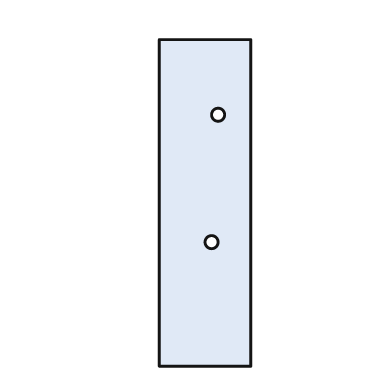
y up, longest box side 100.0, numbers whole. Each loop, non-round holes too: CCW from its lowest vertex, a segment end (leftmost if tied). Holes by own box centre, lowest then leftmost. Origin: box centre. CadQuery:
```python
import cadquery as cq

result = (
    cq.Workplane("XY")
    .moveTo(-14.0, -50.0)
    .lineTo(14.0, -50.0)
    .lineTo(14.0, 50.0)
    .lineTo(-14.0, 50.0)
    .close()
    .moveTo(2.0, -12.0)
    .circle(2.0)
    .moveTo(4.0, 27.0)
    .circle(2.0)
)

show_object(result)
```